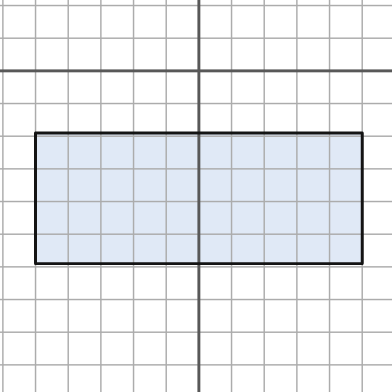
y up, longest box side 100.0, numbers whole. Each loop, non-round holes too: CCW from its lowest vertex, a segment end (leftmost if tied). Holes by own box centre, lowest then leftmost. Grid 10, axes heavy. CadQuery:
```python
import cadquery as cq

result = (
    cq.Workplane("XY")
    .moveTo(-50.0, -59.0)
    .lineTo(50.0, -59.0)
    .lineTo(50.0, -19.0)
    .lineTo(-50.0, -19.0)
    .close()
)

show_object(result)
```